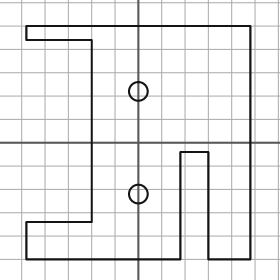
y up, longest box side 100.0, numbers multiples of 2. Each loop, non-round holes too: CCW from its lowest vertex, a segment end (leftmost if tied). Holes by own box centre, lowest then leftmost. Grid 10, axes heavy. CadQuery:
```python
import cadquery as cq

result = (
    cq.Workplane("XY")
    .moveTo(-48.0, -50.0)
    .lineTo(18.0, -50.0)
    .lineTo(18.0, -4.0)
    .lineTo(30.0, -4.0)
    .lineTo(30.0, -50.0)
    .lineTo(48.0, -50.0)
    .lineTo(48.0, 50.0)
    .lineTo(-48.0, 50.0)
    .lineTo(-48.0, 44.0)
    .lineTo(-20.0, 44.0)
    .lineTo(-20.0, -34.0)
    .lineTo(-48.0, -34.0)
    .close()
    .moveTo(0.0, -22.0)
    .circle(4.0)
    .moveTo(0.0, 22.0)
    .circle(4.0)
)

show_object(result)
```